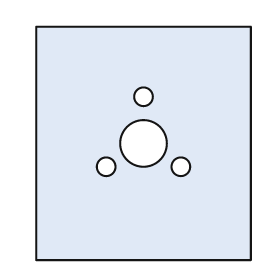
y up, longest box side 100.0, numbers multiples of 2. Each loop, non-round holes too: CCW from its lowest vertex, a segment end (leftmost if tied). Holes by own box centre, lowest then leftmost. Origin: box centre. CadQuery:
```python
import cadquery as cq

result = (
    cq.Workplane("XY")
    .moveTo(-46.0, -50.0)
    .lineTo(46.0, -50.0)
    .lineTo(46.0, 50.0)
    .lineTo(-46.0, 50.0)
    .close()
    .moveTo(-16.0, -10.0)
    .circle(4.0)
    .moveTo(16.0, -10.0)
    .circle(4.0)
    .moveTo(0.0, 0.0)
    .circle(10.0)
    .moveTo(0.0, 20.0)
    .circle(4.0)
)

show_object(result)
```